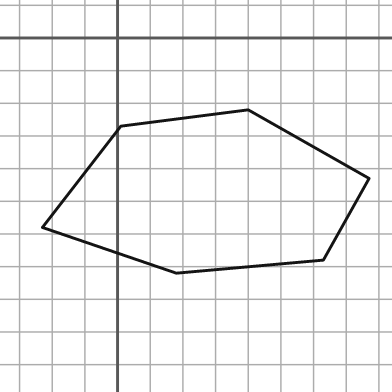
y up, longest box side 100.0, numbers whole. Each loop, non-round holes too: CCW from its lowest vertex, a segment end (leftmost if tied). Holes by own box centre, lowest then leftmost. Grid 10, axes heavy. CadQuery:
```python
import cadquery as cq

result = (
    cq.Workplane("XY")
    .moveTo(18.0, -72.0)
    .lineTo(63.0, -68.0)
    .lineTo(77.0, -43.0)
    .lineTo(40.0, -22.0)
    .lineTo(1.0, -27.0)
    .lineTo(-23.0, -58.0)
    .close()
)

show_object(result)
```